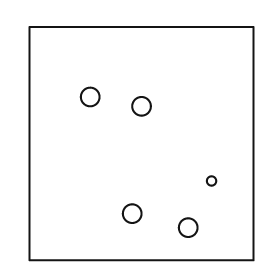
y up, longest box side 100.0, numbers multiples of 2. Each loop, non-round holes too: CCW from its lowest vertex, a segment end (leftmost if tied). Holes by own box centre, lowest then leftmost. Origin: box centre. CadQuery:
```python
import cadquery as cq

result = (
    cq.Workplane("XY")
    .moveTo(-48.0, -50.0)
    .lineTo(48.0, -50.0)
    .lineTo(48.0, 50.0)
    .lineTo(-48.0, 50.0)
    .close()
    .moveTo(20.0, -36.0)
    .circle(4.0)
    .moveTo(-4.0, -30.0)
    .circle(4.0)
    .moveTo(30.0, -16.0)
    .circle(2.0)
    .moveTo(0.0, 16.0)
    .circle(4.0)
    .moveTo(-22.0, 20.0)
    .circle(4.0)
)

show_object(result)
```